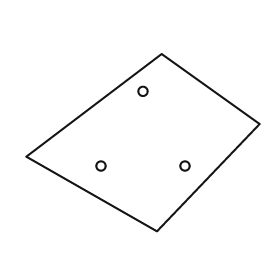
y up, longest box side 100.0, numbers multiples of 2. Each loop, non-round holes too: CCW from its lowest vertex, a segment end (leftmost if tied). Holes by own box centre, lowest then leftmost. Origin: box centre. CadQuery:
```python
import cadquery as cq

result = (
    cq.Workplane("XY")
    .moveTo(6.0, -38.0)
    .lineTo(50.0, 8.0)
    .lineTo(8.0, 38.0)
    .lineTo(-50.0, -6.0)
    .close()
    .moveTo(-18.0, -10.0)
    .circle(2.0)
    .moveTo(18.0, -10.0)
    .circle(2.0)
    .moveTo(0.0, 22.0)
    .circle(2.0)
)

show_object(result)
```